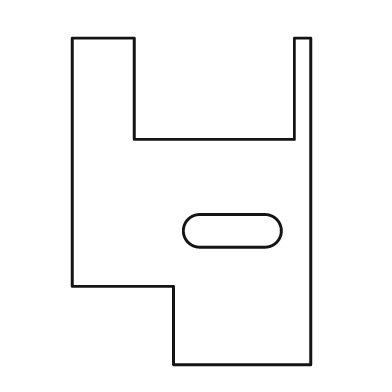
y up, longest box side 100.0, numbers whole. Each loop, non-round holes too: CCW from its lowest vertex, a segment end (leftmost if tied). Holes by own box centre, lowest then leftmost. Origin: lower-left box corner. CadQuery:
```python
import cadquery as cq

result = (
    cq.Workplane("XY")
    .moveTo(31.0, 0.0)
    .lineTo(73.0, 0.0)
    .lineTo(73.0, 100.0)
    .lineTo(68.0, 100.0)
    .lineTo(68.0, 69.0)
    .lineTo(19.0, 69.0)
    .lineTo(19.0, 100.0)
    .lineTo(0.0, 100.0)
    .lineTo(0.0, 24.0)
    .lineTo(31.0, 24.0)
    .close()
    .moveTo(39.0, 36.0)
    .lineTo(59.0, 36.0)
    .threePointArc((64.0, 41.0), (59.0, 46.0))
    .lineTo(39.0, 46.0)
    .threePointArc((34.0, 41.0), (39.0, 36.0))
    .close()
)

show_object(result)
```